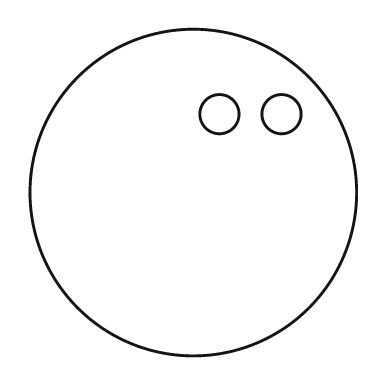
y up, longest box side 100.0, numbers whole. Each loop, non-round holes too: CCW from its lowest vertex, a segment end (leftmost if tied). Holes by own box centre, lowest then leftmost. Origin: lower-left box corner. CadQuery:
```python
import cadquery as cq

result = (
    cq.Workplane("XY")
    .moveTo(50.0, 50.0)
    .circle(50.0)
    .moveTo(58.0, 74.0)
    .circle(6.0)
    .moveTo(77.0, 74.0)
    .circle(6.0)
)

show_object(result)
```